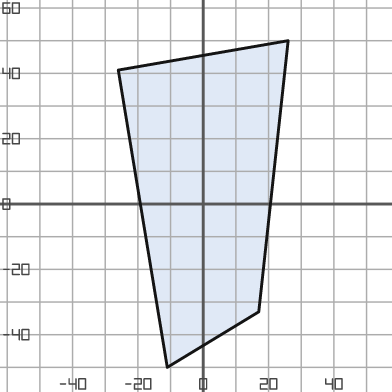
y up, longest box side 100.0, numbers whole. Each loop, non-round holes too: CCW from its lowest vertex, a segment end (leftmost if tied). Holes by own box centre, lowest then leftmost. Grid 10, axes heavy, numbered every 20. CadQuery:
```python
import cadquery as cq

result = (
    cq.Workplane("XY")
    .moveTo(-11.0, -50.0)
    .lineTo(17.0, -33.0)
    .lineTo(26.0, 50.0)
    .lineTo(-26.0, 41.0)
    .close()
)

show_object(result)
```